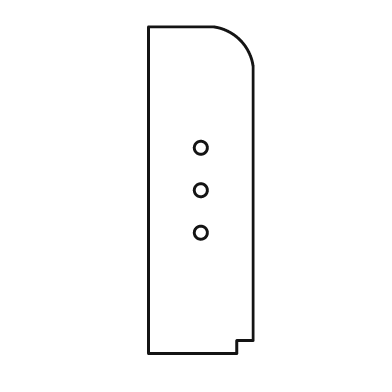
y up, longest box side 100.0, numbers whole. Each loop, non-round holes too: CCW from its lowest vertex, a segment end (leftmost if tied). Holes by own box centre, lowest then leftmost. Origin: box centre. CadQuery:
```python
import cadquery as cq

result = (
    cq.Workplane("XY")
    .moveTo(-16.0, -50.0)
    .lineTo(11.0, -50.0)
    .lineTo(11.0, -46.0)
    .lineTo(16.0, -46.0)
    .lineTo(16.0, 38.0)
    .threePointArc((12.0, 46.0), (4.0, 50.0))
    .lineTo(-16.0, 50.0)
    .close()
    .moveTo(0.0, -13.0)
    .circle(2.0)
    .moveTo(0.0, 0.0)
    .circle(2.0)
    .moveTo(0.0, 13.0)
    .circle(2.0)
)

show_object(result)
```